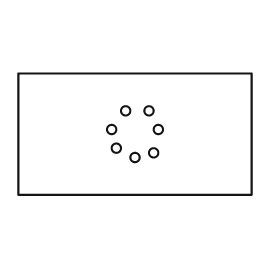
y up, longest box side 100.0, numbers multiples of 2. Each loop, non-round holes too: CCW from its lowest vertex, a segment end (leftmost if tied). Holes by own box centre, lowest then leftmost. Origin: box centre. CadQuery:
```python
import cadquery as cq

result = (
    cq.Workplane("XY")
    .moveTo(-50.0, -26.0)
    .lineTo(50.0, -26.0)
    .lineTo(50.0, 26.0)
    .lineTo(-50.0, 26.0)
    .close()
    .moveTo(0.0, -10.0)
    .circle(2.0)
    .moveTo(8.0, -8.0)
    .circle(2.0)
    .moveTo(-8.0, -6.0)
    .circle(2.0)
    .moveTo(-10.0, 2.0)
    .circle(2.0)
    .moveTo(10.0, 2.0)
    .circle(2.0)
    .moveTo(-4.0, 10.0)
    .circle(2.0)
    .moveTo(6.0, 10.0)
    .circle(2.0)
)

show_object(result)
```